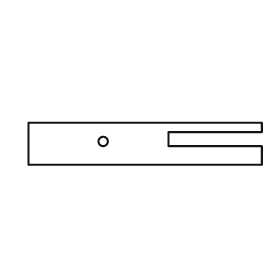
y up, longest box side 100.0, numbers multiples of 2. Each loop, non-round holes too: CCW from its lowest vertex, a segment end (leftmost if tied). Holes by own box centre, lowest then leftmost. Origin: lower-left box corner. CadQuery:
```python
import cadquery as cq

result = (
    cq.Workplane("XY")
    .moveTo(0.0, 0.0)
    .lineTo(100.0, 0.0)
    .lineTo(100.0, 8.0)
    .lineTo(60.0, 8.0)
    .lineTo(60.0, 14.0)
    .lineTo(100.0, 14.0)
    .lineTo(100.0, 18.0)
    .lineTo(0.0, 18.0)
    .close()
    .moveTo(32.0, 10.0)
    .circle(2.0)
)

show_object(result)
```